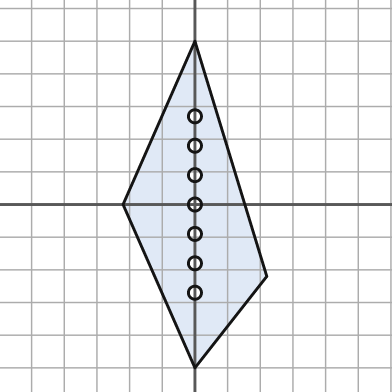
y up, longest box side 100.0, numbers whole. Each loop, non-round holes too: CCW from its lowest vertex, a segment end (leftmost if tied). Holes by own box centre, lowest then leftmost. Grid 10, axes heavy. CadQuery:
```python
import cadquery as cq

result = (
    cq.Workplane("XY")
    .moveTo(0.0, -50.0)
    .lineTo(22.0, -22.0)
    .lineTo(0.0, 50.0)
    .lineTo(-22.0, 0.0)
    .close()
    .moveTo(0.0, -27.0)
    .circle(2.0)
    .moveTo(0.0, -18.0)
    .circle(2.0)
    .moveTo(0.0, -9.0)
    .circle(2.0)
    .moveTo(0.0, 0.0)
    .circle(2.0)
    .moveTo(0.0, 9.0)
    .circle(2.0)
    .moveTo(0.0, 18.0)
    .circle(2.0)
    .moveTo(0.0, 27.0)
    .circle(2.0)
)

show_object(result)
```